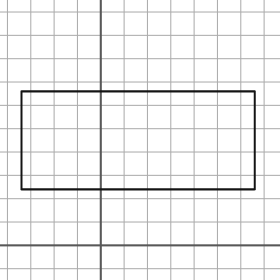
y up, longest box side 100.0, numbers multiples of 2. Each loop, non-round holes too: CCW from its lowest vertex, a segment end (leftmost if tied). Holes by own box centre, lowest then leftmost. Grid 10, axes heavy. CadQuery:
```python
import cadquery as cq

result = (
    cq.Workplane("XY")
    .moveTo(-34.0, 24.0)
    .lineTo(66.0, 24.0)
    .lineTo(66.0, 66.0)
    .lineTo(-34.0, 66.0)
    .close()
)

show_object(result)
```